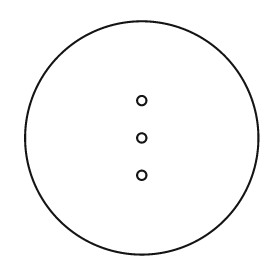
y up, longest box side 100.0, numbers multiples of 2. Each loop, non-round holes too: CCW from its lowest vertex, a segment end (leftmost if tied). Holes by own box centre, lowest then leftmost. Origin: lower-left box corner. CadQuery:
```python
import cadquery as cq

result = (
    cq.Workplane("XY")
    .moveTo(50.0, 50.0)
    .circle(50.0)
    .moveTo(50.0, 34.0)
    .circle(2.0)
    .moveTo(50.0, 50.0)
    .circle(2.0)
    .moveTo(50.0, 66.0)
    .circle(2.0)
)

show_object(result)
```